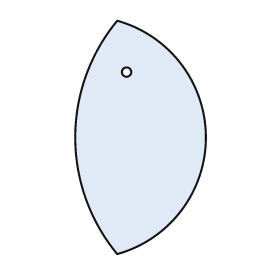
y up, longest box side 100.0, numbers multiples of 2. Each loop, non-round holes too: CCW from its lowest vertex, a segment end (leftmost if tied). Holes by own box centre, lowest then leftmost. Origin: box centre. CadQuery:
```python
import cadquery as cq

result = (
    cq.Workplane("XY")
    .moveTo(-10.0, -50.0)
    .threePointArc((28.0, 0.0), (-10.0, 50.0))
    .threePointArc((-28.0, 0.0), (-10.0, -50.0))
    .close()
    .moveTo(-6.0, 28.0)
    .circle(2.0)
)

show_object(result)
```